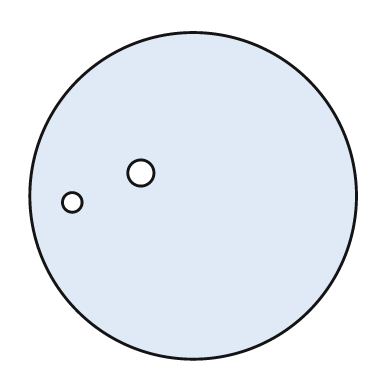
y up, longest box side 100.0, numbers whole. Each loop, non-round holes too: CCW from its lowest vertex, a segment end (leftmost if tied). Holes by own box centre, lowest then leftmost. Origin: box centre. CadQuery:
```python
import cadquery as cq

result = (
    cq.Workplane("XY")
    .moveTo(0.0, 0.0)
    .circle(50.0)
    .moveTo(-37.0, -2.0)
    .circle(3.0)
    .moveTo(-16.0, 7.0)
    .circle(4.0)
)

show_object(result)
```